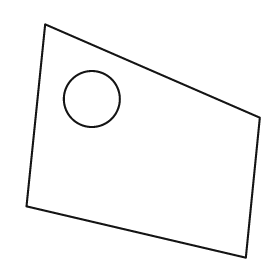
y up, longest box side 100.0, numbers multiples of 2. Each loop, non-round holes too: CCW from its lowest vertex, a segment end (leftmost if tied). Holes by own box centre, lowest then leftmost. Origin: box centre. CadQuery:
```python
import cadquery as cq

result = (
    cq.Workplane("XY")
    .moveTo(44.0, -50.0)
    .lineTo(50.0, 10.0)
    .lineTo(-42.0, 50.0)
    .lineTo(-50.0, -28.0)
    .close()
    .moveTo(-22.0, 18.0)
    .circle(12.0)
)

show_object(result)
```